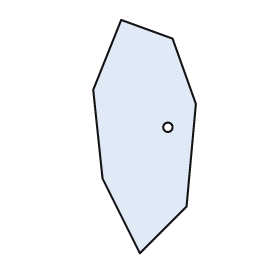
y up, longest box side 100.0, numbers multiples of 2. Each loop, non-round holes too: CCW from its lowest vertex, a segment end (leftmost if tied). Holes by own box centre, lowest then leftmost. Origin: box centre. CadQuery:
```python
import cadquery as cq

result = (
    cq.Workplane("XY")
    .moveTo(-2.0, -50.0)
    .lineTo(18.0, -30.0)
    .lineTo(22.0, 14.0)
    .lineTo(12.0, 42.0)
    .lineTo(-10.0, 50.0)
    .lineTo(-22.0, 20.0)
    .lineTo(-18.0, -18.0)
    .close()
    .moveTo(10.0, 4.0)
    .circle(2.0)
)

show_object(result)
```